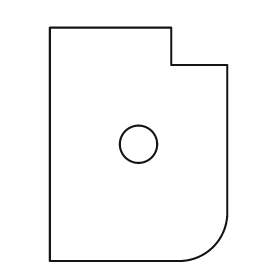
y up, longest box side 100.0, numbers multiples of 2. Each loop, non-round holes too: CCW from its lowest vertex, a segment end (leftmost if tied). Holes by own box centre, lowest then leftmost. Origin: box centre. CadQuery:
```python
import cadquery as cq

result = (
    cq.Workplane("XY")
    .moveTo(-38.0, -50.0)
    .lineTo(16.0, -50.0)
    .threePointArc((32.0, -44.0), (38.0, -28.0))
    .lineTo(38.0, 34.0)
    .lineTo(14.0, 34.0)
    .lineTo(14.0, 50.0)
    .lineTo(-38.0, 50.0)
    .close()
    .moveTo(0.0, 0.0)
    .circle(8.0)
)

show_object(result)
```